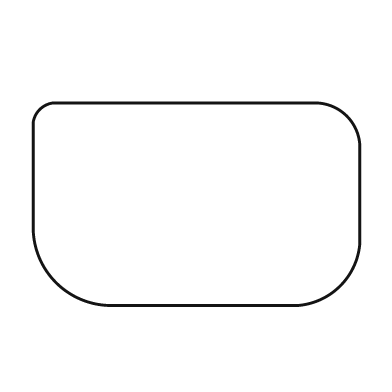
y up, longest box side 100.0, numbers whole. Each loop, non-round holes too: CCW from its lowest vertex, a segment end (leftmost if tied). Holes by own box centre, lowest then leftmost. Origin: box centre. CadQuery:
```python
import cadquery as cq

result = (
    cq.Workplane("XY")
    .moveTo(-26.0, -31.0)
    .lineTo(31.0, -31.0)
    .threePointArc((44.0, -25.0), (50.0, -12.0))
    .lineTo(50.0, 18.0)
    .threePointArc((46.0, 27.0), (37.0, 31.0))
    .lineTo(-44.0, 31.0)
    .threePointArc((-48.0, 29.0), (-50.0, 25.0))
    .lineTo(-50.0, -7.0)
    .threePointArc((-43.0, -24.0), (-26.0, -31.0))
    .close()
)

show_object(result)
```